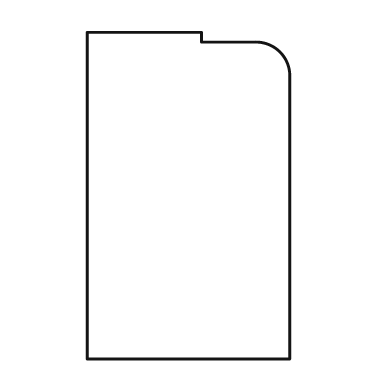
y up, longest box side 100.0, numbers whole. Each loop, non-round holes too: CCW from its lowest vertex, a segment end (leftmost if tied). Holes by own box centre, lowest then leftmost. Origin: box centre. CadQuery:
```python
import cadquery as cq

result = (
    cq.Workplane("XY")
    .moveTo(-31.0, -50.0)
    .lineTo(31.0, -50.0)
    .lineTo(31.0, 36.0)
    .threePointArc((28.0, 44.0), (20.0, 47.0))
    .lineTo(4.0, 47.0)
    .lineTo(4.0, 50.0)
    .lineTo(-31.0, 50.0)
    .close()
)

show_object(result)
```